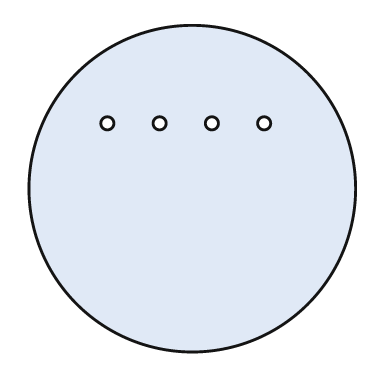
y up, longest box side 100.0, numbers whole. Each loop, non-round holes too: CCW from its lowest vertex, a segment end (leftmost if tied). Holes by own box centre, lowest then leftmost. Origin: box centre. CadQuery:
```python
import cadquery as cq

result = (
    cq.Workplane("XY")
    .moveTo(0.0, 0.0)
    .circle(50.0)
    .moveTo(-26.0, 20.0)
    .circle(2.0)
    .moveTo(-10.0, 20.0)
    .circle(2.0)
    .moveTo(6.0, 20.0)
    .circle(2.0)
    .moveTo(22.0, 20.0)
    .circle(2.0)
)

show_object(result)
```